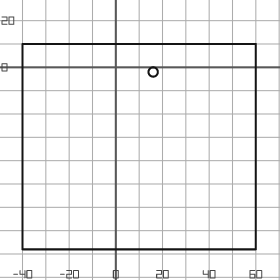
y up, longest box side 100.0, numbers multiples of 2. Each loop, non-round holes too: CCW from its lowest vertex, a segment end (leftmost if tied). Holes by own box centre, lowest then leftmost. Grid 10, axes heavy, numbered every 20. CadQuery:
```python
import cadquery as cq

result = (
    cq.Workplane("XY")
    .moveTo(-40.0, -78.0)
    .lineTo(60.0, -78.0)
    .lineTo(60.0, 10.0)
    .lineTo(-40.0, 10.0)
    .close()
    .moveTo(16.0, -2.0)
    .circle(2.0)
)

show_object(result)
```